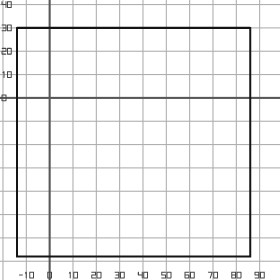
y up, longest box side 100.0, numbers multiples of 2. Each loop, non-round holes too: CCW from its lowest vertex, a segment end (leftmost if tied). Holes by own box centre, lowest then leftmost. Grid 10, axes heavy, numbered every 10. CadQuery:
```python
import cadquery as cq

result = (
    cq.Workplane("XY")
    .moveTo(-14.0, -68.0)
    .lineTo(86.0, -68.0)
    .lineTo(86.0, 30.0)
    .lineTo(-14.0, 30.0)
    .close()
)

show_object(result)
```